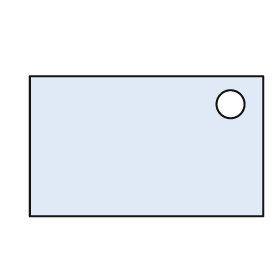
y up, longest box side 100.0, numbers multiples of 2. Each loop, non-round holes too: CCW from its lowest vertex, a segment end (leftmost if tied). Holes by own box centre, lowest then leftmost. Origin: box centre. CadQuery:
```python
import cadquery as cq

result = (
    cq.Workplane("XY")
    .moveTo(-50.0, -30.0)
    .lineTo(50.0, -30.0)
    .lineTo(50.0, 30.0)
    .lineTo(-50.0, 30.0)
    .close()
    .moveTo(36.0, 18.0)
    .circle(6.0)
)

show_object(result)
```